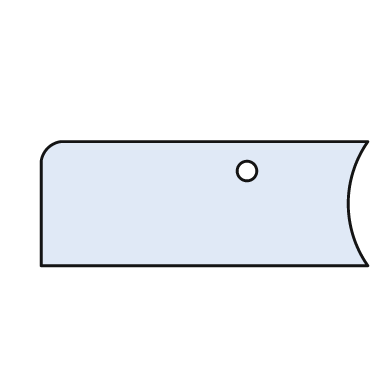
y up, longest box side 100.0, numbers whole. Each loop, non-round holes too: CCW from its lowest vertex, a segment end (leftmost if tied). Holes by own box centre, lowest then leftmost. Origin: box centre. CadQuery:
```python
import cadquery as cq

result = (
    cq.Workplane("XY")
    .moveTo(-50.0, -19.0)
    .lineTo(50.0, -19.0)
    .threePointArc((44.0, 0.0), (50.0, 19.0))
    .lineTo(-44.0, 19.0)
    .threePointArc((-48.0, 17.0), (-50.0, 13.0))
    .close()
    .moveTo(13.0, 10.0)
    .circle(3.0)
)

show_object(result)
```